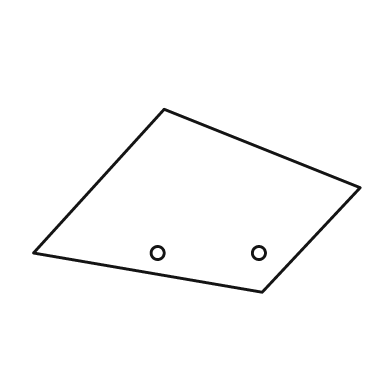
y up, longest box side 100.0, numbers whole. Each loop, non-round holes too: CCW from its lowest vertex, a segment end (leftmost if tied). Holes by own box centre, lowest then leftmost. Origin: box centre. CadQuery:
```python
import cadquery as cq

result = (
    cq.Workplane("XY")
    .moveTo(20.0, -28.0)
    .lineTo(50.0, 4.0)
    .lineTo(-10.0, 28.0)
    .lineTo(-50.0, -16.0)
    .close()
    .moveTo(-12.0, -16.0)
    .circle(2.0)
    .moveTo(19.0, -16.0)
    .circle(2.0)
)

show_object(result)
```